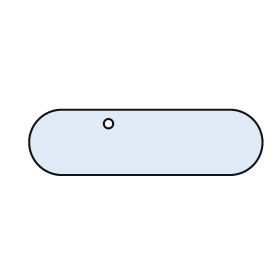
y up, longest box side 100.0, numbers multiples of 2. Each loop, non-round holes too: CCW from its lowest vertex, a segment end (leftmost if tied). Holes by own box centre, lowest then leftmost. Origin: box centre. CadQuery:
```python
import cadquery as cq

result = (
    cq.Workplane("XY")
    .moveTo(-36.0, -14.0)
    .lineTo(36.0, -14.0)
    .threePointArc((50.0, 0.0), (36.0, 14.0))
    .lineTo(-36.0, 14.0)
    .threePointArc((-50.0, 0.0), (-36.0, -14.0))
    .close()
    .moveTo(-16.0, 8.0)
    .circle(2.0)
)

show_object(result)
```